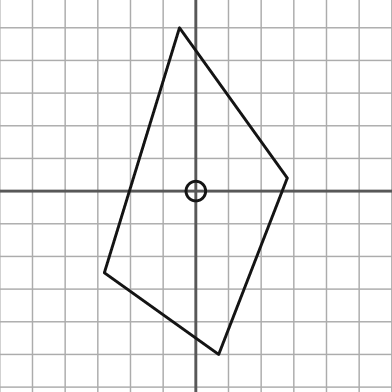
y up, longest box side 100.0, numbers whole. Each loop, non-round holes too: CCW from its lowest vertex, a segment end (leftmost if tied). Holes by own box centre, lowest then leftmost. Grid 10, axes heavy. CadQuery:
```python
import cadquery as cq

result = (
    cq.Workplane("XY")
    .moveTo(7.0, -50.0)
    .lineTo(28.0, 4.0)
    .lineTo(-5.0, 50.0)
    .lineTo(-28.0, -25.0)
    .close()
    .moveTo(0.0, 0.0)
    .circle(3.0)
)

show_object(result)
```